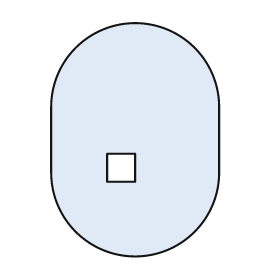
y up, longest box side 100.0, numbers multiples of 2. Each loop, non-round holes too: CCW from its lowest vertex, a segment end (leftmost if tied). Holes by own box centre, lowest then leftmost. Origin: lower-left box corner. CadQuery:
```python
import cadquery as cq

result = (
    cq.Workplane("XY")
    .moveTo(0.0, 36.0)
    .threePointArc((36.0, 0.0), (72.0, 36.0))
    .lineTo(72.0, 64.0)
    .threePointArc((36.0, 100.0), (0.0, 64.0))
    .close()
    .moveTo(24.0, 32.0)
    .lineTo(36.0, 32.0)
    .lineTo(36.0, 44.0)
    .lineTo(24.0, 44.0)
    .close()
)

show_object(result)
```